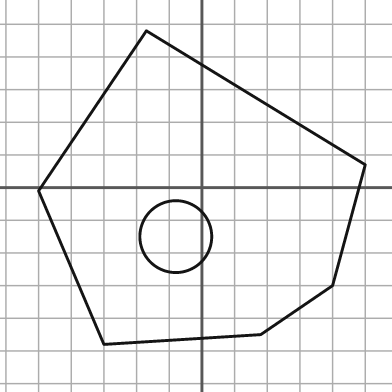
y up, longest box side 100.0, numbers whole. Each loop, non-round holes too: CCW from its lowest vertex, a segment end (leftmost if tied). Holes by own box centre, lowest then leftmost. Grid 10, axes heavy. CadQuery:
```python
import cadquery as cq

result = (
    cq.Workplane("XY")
    .moveTo(-30.0, -48.0)
    .lineTo(18.0, -45.0)
    .lineTo(40.0, -30.0)
    .lineTo(50.0, 7.0)
    .lineTo(-17.0, 48.0)
    .lineTo(-50.0, -1.0)
    .close()
    .moveTo(-8.0, -15.0)
    .circle(11.0)
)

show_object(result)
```